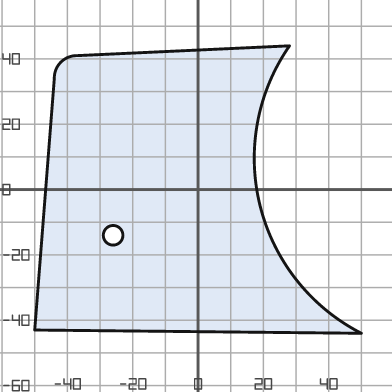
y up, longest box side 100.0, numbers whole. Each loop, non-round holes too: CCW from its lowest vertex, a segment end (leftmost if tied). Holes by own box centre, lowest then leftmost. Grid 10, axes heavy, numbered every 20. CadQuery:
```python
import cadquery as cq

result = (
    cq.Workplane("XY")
    .moveTo(50.0, -44.0)
    .threePointArc((19.0, -5.0), (28.0, 44.0))
    .lineTo(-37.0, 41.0)
    .threePointArc((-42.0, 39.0), (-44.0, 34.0))
    .lineTo(-50.0, -43.0)
    .close()
    .moveTo(-26.0, -14.0)
    .circle(3.0)
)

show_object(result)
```